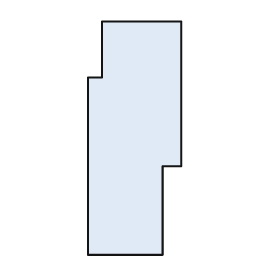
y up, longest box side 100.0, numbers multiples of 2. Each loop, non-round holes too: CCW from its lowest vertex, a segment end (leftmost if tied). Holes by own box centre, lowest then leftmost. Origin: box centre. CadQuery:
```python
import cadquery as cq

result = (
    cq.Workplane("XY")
    .moveTo(-20.0, -50.0)
    .lineTo(12.0, -50.0)
    .lineTo(12.0, -12.0)
    .lineTo(20.0, -12.0)
    .lineTo(20.0, 50.0)
    .lineTo(-14.0, 50.0)
    .lineTo(-14.0, 26.0)
    .lineTo(-20.0, 26.0)
    .close()
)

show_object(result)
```